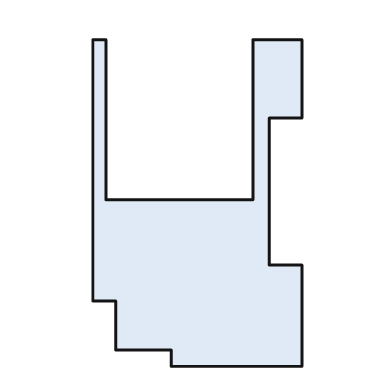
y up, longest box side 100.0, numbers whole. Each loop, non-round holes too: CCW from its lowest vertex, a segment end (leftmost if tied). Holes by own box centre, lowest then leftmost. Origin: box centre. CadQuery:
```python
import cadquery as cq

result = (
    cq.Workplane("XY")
    .moveTo(-8.0, -50.0)
    .lineTo(32.0, -50.0)
    .lineTo(32.0, -19.0)
    .lineTo(22.0, -19.0)
    .lineTo(22.0, 26.0)
    .lineTo(32.0, 26.0)
    .lineTo(32.0, 50.0)
    .lineTo(17.0, 50.0)
    .lineTo(17.0, 1.0)
    .lineTo(-28.0, 1.0)
    .lineTo(-28.0, 50.0)
    .lineTo(-32.0, 50.0)
    .lineTo(-32.0, -30.0)
    .lineTo(-25.0, -30.0)
    .lineTo(-25.0, -45.0)
    .lineTo(-8.0, -45.0)
    .close()
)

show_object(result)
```